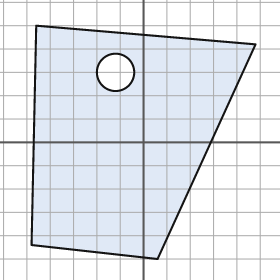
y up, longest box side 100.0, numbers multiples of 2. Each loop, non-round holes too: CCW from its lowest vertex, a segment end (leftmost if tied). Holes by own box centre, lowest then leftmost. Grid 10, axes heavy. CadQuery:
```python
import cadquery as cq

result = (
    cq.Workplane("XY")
    .moveTo(6.0, -50.0)
    .lineTo(48.0, 42.0)
    .lineTo(-46.0, 50.0)
    .lineTo(-48.0, -44.0)
    .close()
    .moveTo(-12.0, 30.0)
    .circle(8.0)
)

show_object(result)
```